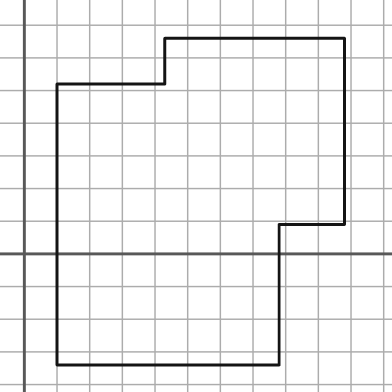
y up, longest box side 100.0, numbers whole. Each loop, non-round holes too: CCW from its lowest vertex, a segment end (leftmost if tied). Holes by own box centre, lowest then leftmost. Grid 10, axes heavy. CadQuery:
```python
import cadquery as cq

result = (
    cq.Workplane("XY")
    .moveTo(10.0, -34.0)
    .lineTo(78.0, -34.0)
    .lineTo(78.0, 9.0)
    .lineTo(98.0, 9.0)
    .lineTo(98.0, 66.0)
    .lineTo(43.0, 66.0)
    .lineTo(43.0, 52.0)
    .lineTo(10.0, 52.0)
    .close()
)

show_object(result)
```